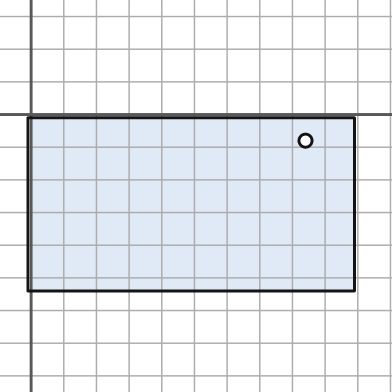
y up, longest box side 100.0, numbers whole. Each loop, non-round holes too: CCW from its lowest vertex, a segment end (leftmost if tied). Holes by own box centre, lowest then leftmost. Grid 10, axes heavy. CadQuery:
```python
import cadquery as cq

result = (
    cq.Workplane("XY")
    .moveTo(-1.0, -54.0)
    .lineTo(99.0, -54.0)
    .lineTo(99.0, -1.0)
    .lineTo(-1.0, -1.0)
    .close()
    .moveTo(84.0, -8.0)
    .circle(2.0)
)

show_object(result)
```